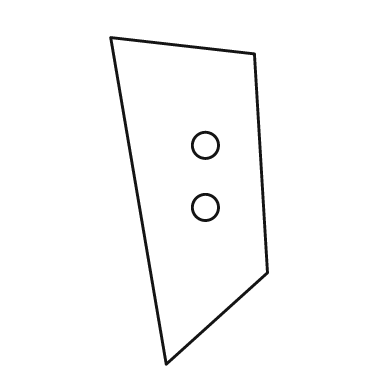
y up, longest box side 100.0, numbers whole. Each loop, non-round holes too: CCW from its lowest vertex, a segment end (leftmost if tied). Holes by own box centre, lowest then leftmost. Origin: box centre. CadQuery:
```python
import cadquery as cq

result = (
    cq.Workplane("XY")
    .moveTo(-7.0, -50.0)
    .lineTo(24.0, -22.0)
    .lineTo(20.0, 45.0)
    .lineTo(-24.0, 50.0)
    .close()
    .moveTo(5.0, -2.0)
    .circle(4.0)
    .moveTo(5.0, 17.0)
    .circle(4.0)
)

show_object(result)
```